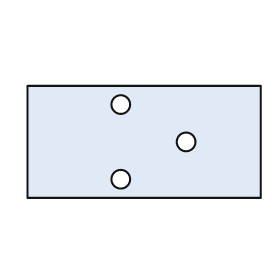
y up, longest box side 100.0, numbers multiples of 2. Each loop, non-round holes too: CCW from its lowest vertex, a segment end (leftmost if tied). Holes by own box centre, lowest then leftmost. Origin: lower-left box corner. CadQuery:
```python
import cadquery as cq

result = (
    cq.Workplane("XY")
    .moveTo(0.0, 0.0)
    .lineTo(100.0, 0.0)
    .lineTo(100.0, 48.0)
    .lineTo(0.0, 48.0)
    .close()
    .moveTo(40.0, 8.0)
    .circle(4.0)
    .moveTo(68.0, 24.0)
    .circle(4.0)
    .moveTo(40.0, 40.0)
    .circle(4.0)
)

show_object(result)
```